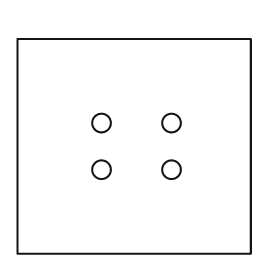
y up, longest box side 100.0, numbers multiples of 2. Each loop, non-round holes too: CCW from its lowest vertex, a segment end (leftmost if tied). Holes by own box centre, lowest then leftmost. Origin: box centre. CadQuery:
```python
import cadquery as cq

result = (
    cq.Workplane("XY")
    .moveTo(-50.0, -46.0)
    .lineTo(50.0, -46.0)
    .lineTo(50.0, 46.0)
    .lineTo(-50.0, 46.0)
    .close()
    .moveTo(-14.0, -10.0)
    .circle(4.0)
    .moveTo(16.0, -10.0)
    .circle(4.0)
    .moveTo(-14.0, 10.0)
    .circle(4.0)
    .moveTo(16.0, 10.0)
    .circle(4.0)
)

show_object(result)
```